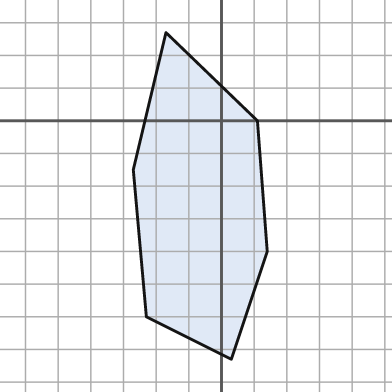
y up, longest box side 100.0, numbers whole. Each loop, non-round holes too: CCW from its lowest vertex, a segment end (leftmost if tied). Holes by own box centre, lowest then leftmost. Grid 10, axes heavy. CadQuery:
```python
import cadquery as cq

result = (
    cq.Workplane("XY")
    .moveTo(3.0, -73.0)
    .lineTo(14.0, -40.0)
    .lineTo(11.0, 0.0)
    .lineTo(-17.0, 27.0)
    .lineTo(-27.0, -15.0)
    .lineTo(-23.0, -60.0)
    .close()
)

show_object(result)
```